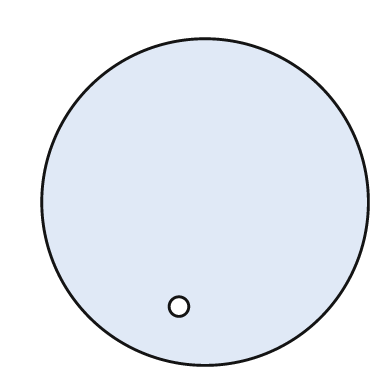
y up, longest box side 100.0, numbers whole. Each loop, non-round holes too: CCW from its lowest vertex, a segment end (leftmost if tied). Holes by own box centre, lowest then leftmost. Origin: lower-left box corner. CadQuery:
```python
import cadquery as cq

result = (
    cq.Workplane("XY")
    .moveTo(50.0, 50.0)
    .circle(50.0)
    .moveTo(42.0, 18.0)
    .circle(3.0)
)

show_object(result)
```